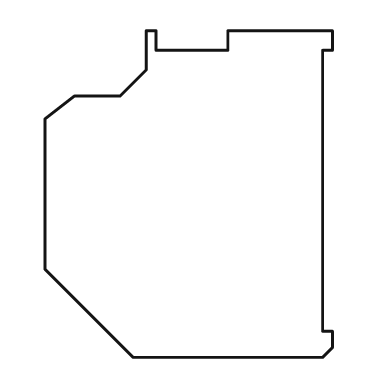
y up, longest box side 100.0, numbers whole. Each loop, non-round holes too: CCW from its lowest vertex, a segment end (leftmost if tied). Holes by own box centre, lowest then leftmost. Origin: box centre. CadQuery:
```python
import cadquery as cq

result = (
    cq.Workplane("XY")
    .moveTo(-17.0, -50.0)
    .lineTo(41.0, -50.0)
    .lineTo(44.0, -47.0)
    .lineTo(44.0, -42.0)
    .lineTo(41.0, -42.0)
    .lineTo(41.0, 44.0)
    .lineTo(44.0, 44.0)
    .lineTo(44.0, 50.0)
    .lineTo(12.0, 50.0)
    .lineTo(12.0, 44.0)
    .lineTo(-10.0, 44.0)
    .lineTo(-10.0, 50.0)
    .lineTo(-13.0, 50.0)
    .lineTo(-13.0, 38.0)
    .lineTo(-21.0, 30.0)
    .lineTo(-35.0, 30.0)
    .lineTo(-44.0, 23.0)
    .lineTo(-44.0, -23.0)
    .close()
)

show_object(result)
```